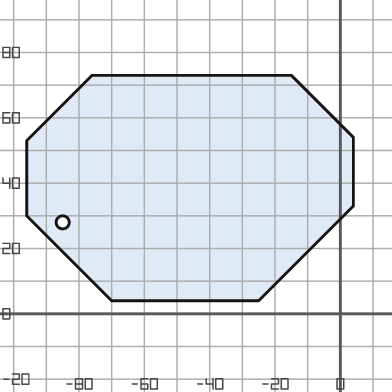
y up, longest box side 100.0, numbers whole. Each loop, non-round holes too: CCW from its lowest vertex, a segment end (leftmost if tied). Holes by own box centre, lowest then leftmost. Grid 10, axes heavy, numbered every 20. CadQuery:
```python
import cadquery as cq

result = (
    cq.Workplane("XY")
    .moveTo(-70.0, 4.0)
    .lineTo(-25.0, 4.0)
    .lineTo(4.0, 33.0)
    .lineTo(4.0, 54.0)
    .lineTo(-15.0, 73.0)
    .lineTo(-76.0, 73.0)
    .lineTo(-96.0, 53.0)
    .lineTo(-96.0, 30.0)
    .close()
    .moveTo(-85.0, 28.0)
    .circle(2.0)
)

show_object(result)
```